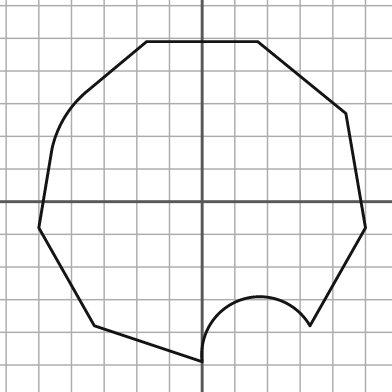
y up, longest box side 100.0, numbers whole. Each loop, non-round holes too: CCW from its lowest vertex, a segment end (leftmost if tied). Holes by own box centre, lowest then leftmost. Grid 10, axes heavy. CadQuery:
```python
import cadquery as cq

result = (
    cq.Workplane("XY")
    .moveTo(0.0, -49.0)
    .threePointArc((12.0, -30.0), (33.0, -38.0))
    .lineTo(50.0, -8.0)
    .lineTo(44.0, 27.0)
    .lineTo(17.0, 49.0)
    .lineTo(-17.0, 49.0)
    .lineTo(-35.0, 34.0)
    .threePointArc((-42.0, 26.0), (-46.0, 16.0))
    .lineTo(-50.0, -8.0)
    .lineTo(-33.0, -38.0)
    .close()
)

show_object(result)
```